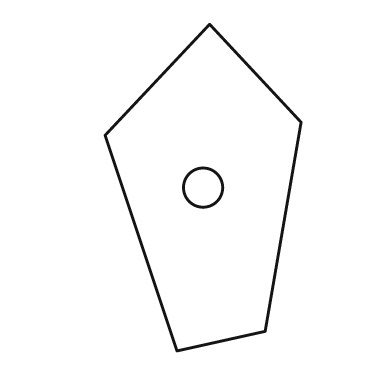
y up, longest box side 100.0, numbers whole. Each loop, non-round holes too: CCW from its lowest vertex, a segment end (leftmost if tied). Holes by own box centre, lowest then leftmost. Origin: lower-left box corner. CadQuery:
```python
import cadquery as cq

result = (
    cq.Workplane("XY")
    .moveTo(22.0, 0.0)
    .lineTo(49.0, 6.0)
    .lineTo(60.0, 70.0)
    .lineTo(32.0, 100.0)
    .lineTo(0.0, 66.0)
    .close()
    .moveTo(30.0, 50.0)
    .circle(6.0)
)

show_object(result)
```